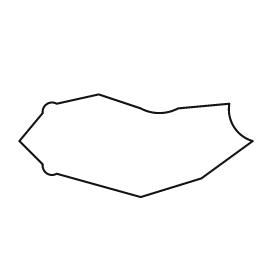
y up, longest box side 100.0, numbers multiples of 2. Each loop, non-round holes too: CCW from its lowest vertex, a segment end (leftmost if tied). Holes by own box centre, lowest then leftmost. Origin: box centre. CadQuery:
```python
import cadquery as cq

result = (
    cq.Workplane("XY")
    .moveTo(2.0, -22.0)
    .lineTo(28.0, -14.0)
    .lineTo(50.0, 2.0)
    .threePointArc((42.0, 8.0), (40.0, 18.0))
    .lineTo(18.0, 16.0)
    .threePointArc((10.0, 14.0), (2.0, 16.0))
    .lineTo(-16.0, 22.0)
    .lineTo(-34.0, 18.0)
    .threePointArc((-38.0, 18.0), (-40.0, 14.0))
    .lineTo(-50.0, 2.0)
    .lineTo(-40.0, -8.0)
    .threePointArc((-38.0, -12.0), (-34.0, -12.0))
    .close()
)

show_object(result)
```